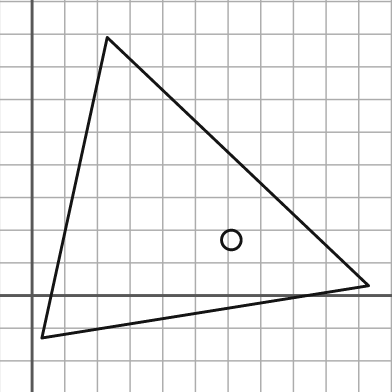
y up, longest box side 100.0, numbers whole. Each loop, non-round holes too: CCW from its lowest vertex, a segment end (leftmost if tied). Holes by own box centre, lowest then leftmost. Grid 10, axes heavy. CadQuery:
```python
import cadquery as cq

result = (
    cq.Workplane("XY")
    .moveTo(3.0, -13.0)
    .lineTo(103.0, 3.0)
    .lineTo(23.0, 79.0)
    .close()
    .moveTo(61.0, 17.0)
    .circle(3.0)
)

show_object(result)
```